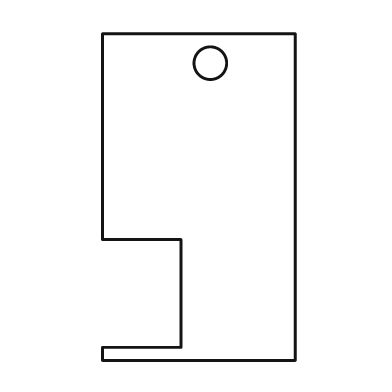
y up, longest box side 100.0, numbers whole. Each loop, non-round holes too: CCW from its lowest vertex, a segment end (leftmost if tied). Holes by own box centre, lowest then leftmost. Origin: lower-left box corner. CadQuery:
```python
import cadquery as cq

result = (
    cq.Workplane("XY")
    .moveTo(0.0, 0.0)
    .lineTo(59.0, 0.0)
    .lineTo(59.0, 100.0)
    .lineTo(0.0, 100.0)
    .lineTo(0.0, 37.0)
    .lineTo(24.0, 37.0)
    .lineTo(24.0, 4.0)
    .lineTo(0.0, 4.0)
    .close()
    .moveTo(33.0, 91.0)
    .circle(5.0)
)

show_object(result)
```